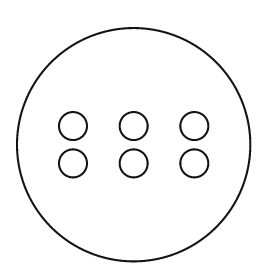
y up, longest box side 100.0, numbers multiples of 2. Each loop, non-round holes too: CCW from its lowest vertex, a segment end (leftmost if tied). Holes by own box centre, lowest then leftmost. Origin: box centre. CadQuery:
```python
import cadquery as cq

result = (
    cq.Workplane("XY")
    .moveTo(0.0, 0.0)
    .circle(50.0)
    .moveTo(-26.0, -8.0)
    .circle(6.0)
    .moveTo(0.0, -8.0)
    .circle(6.0)
    .moveTo(26.0, -8.0)
    .circle(6.0)
    .moveTo(-26.0, 8.0)
    .circle(6.0)
    .moveTo(0.0, 8.0)
    .circle(6.0)
    .moveTo(26.0, 8.0)
    .circle(6.0)
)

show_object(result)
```